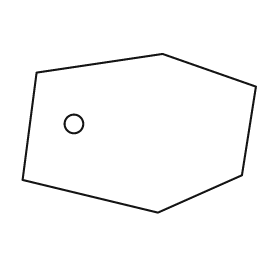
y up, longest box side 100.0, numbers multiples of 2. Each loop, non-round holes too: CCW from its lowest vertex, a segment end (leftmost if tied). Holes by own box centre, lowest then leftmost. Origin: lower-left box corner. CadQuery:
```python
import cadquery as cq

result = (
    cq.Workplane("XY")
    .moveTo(58.0, 0.0)
    .lineTo(94.0, 16.0)
    .lineTo(100.0, 54.0)
    .lineTo(60.0, 68.0)
    .lineTo(6.0, 60.0)
    .lineTo(0.0, 14.0)
    .close()
    .moveTo(22.0, 38.0)
    .circle(4.0)
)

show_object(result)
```